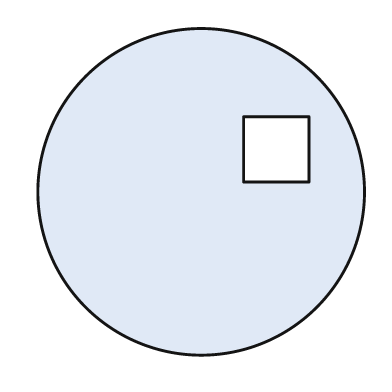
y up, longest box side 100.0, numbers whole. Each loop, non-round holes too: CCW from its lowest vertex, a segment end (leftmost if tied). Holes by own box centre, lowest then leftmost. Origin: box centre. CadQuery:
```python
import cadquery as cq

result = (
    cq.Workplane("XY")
    .moveTo(0.0, 0.0)
    .circle(50.0)
    .moveTo(13.0, 3.0)
    .lineTo(33.0, 3.0)
    .lineTo(33.0, 23.0)
    .lineTo(13.0, 23.0)
    .close()
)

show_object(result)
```